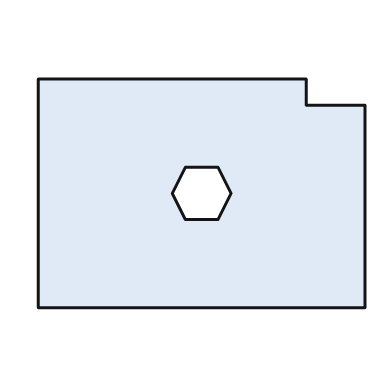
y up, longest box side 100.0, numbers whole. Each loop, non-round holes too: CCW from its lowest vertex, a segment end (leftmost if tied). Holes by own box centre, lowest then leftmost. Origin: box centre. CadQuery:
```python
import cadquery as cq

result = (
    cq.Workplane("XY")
    .moveTo(-50.0, -35.0)
    .lineTo(50.0, -35.0)
    .lineTo(50.0, 27.0)
    .lineTo(32.0, 27.0)
    .lineTo(32.0, 35.0)
    .lineTo(-50.0, 35.0)
    .close()
    .moveTo(-5.0, -8.0)
    .lineTo(5.0, -8.0)
    .lineTo(9.0, 0.0)
    .lineTo(5.0, 8.0)
    .lineTo(-5.0, 8.0)
    .lineTo(-9.0, 0.0)
    .close()
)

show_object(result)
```